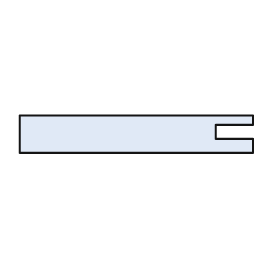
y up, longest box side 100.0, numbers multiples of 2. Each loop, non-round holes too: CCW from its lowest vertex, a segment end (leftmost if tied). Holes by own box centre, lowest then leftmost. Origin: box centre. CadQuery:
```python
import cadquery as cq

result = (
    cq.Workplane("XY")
    .moveTo(-50.0, -8.0)
    .lineTo(50.0, -8.0)
    .lineTo(50.0, -2.0)
    .lineTo(34.0, -2.0)
    .lineTo(34.0, 4.0)
    .lineTo(50.0, 4.0)
    .lineTo(50.0, 8.0)
    .lineTo(-50.0, 8.0)
    .close()
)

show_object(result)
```